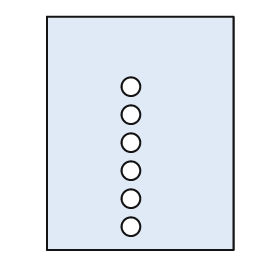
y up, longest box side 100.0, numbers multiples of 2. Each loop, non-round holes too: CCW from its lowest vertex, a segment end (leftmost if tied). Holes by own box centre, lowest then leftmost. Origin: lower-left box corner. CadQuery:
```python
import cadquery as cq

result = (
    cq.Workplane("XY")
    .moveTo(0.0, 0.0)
    .lineTo(80.0, 0.0)
    .lineTo(80.0, 100.0)
    .lineTo(0.0, 100.0)
    .close()
    .moveTo(36.0, 10.0)
    .circle(4.0)
    .moveTo(36.0, 22.0)
    .circle(4.0)
    .moveTo(36.0, 34.0)
    .circle(4.0)
    .moveTo(36.0, 46.0)
    .circle(4.0)
    .moveTo(36.0, 58.0)
    .circle(4.0)
    .moveTo(36.0, 70.0)
    .circle(4.0)
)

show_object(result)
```